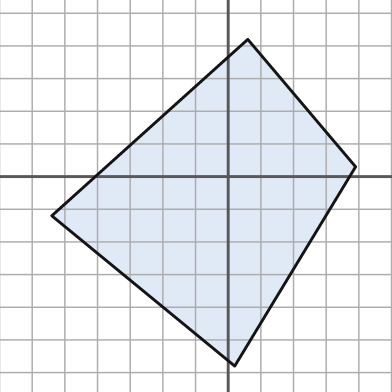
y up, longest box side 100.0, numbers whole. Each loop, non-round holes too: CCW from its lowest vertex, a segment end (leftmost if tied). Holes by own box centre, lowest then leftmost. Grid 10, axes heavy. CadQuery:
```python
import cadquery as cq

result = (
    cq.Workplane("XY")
    .moveTo(2.0, -58.0)
    .lineTo(39.0, 3.0)
    .lineTo(6.0, 42.0)
    .lineTo(-54.0, -12.0)
    .close()
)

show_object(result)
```